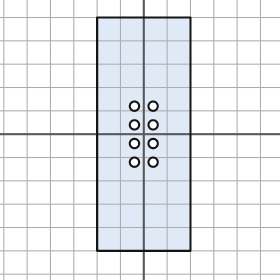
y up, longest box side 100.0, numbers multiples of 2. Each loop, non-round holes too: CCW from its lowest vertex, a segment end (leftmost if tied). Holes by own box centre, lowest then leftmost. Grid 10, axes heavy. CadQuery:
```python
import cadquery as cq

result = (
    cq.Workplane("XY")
    .moveTo(-20.0, -50.0)
    .lineTo(20.0, -50.0)
    .lineTo(20.0, 50.0)
    .lineTo(-20.0, 50.0)
    .close()
    .moveTo(-4.0, -12.0)
    .circle(2.0)
    .moveTo(4.0, -12.0)
    .circle(2.0)
    .moveTo(-4.0, -4.0)
    .circle(2.0)
    .moveTo(4.0, -4.0)
    .circle(2.0)
    .moveTo(-4.0, 4.0)
    .circle(2.0)
    .moveTo(4.0, 4.0)
    .circle(2.0)
    .moveTo(-4.0, 12.0)
    .circle(2.0)
    .moveTo(4.0, 12.0)
    .circle(2.0)
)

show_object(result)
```